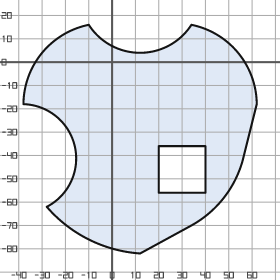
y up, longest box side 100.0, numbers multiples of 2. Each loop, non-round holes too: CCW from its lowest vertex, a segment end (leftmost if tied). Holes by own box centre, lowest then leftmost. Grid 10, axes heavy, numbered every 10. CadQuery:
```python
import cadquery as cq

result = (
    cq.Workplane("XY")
    .moveTo(12.0, -82.0)
    .lineTo(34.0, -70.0)
    .threePointArc((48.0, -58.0), (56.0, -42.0))
    .lineTo(62.0, -18.0)
    .threePointArc((54.0, 4.0), (34.0, 16.0))
    .threePointArc((12.0, 4.0), (-10.0, 16.0))
    .threePointArc((-30.0, 4.0), (-38.0, -18.0))
    .threePointArc((-16.0, -36.0), (-28.0, -62.0))
    .threePointArc((-10.0, -76.0), (12.0, -82.0))
    .close()
    .moveTo(20.0, -56.0)
    .lineTo(40.0, -56.0)
    .lineTo(40.0, -36.0)
    .lineTo(20.0, -36.0)
    .close()
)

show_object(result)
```